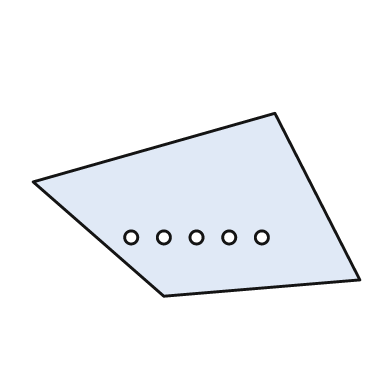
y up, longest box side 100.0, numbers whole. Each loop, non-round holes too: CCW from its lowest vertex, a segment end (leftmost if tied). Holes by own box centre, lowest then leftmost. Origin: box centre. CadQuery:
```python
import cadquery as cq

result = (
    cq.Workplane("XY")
    .moveTo(-10.0, -28.0)
    .lineTo(50.0, -23.0)
    .lineTo(24.0, 28.0)
    .lineTo(-50.0, 7.0)
    .close()
    .moveTo(-20.0, -10.0)
    .circle(2.0)
    .moveTo(-10.0, -10.0)
    .circle(2.0)
    .moveTo(0.0, -10.0)
    .circle(2.0)
    .moveTo(10.0, -10.0)
    .circle(2.0)
    .moveTo(20.0, -10.0)
    .circle(2.0)
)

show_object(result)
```